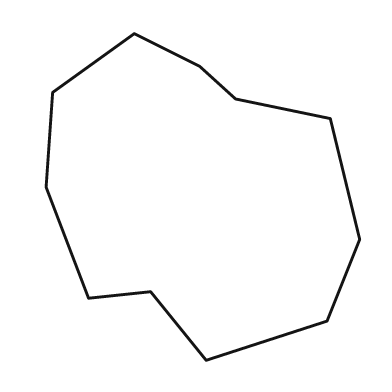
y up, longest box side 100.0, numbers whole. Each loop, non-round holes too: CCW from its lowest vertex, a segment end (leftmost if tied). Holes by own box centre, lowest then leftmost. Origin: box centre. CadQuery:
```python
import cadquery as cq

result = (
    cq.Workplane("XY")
    .moveTo(1.0, -50.0)
    .lineTo(38.0, -38.0)
    .lineTo(48.0, -13.0)
    .lineTo(39.0, 24.0)
    .lineTo(10.0, 30.0)
    .lineTo(-1.0, 40.0)
    .lineTo(-21.0, 50.0)
    .lineTo(-46.0, 32.0)
    .lineTo(-48.0, 3.0)
    .lineTo(-35.0, -31.0)
    .lineTo(-16.0, -29.0)
    .close()
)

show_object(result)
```